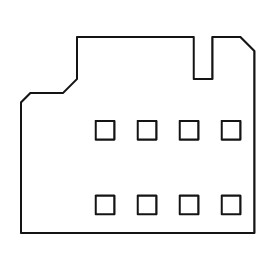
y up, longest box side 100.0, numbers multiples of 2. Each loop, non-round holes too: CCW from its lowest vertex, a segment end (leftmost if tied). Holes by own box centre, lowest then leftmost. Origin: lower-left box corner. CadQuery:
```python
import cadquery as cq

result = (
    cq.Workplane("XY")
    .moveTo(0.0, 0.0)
    .lineTo(100.0, 0.0)
    .lineTo(100.0, 78.0)
    .lineTo(94.0, 84.0)
    .lineTo(82.0, 84.0)
    .lineTo(82.0, 66.0)
    .lineTo(74.0, 66.0)
    .lineTo(74.0, 84.0)
    .lineTo(24.0, 84.0)
    .lineTo(24.0, 66.0)
    .lineTo(18.0, 60.0)
    .lineTo(4.0, 60.0)
    .lineTo(0.0, 56.0)
    .close()
    .moveTo(32.0, 8.0)
    .lineTo(40.0, 8.0)
    .lineTo(40.0, 16.0)
    .lineTo(32.0, 16.0)
    .close()
    .moveTo(50.0, 8.0)
    .lineTo(58.0, 8.0)
    .lineTo(58.0, 16.0)
    .lineTo(50.0, 16.0)
    .close()
    .moveTo(68.0, 8.0)
    .lineTo(76.0, 8.0)
    .lineTo(76.0, 16.0)
    .lineTo(68.0, 16.0)
    .close()
    .moveTo(86.0, 8.0)
    .lineTo(94.0, 8.0)
    .lineTo(94.0, 16.0)
    .lineTo(86.0, 16.0)
    .close()
    .moveTo(32.0, 40.0)
    .lineTo(40.0, 40.0)
    .lineTo(40.0, 48.0)
    .lineTo(32.0, 48.0)
    .close()
    .moveTo(50.0, 40.0)
    .lineTo(58.0, 40.0)
    .lineTo(58.0, 48.0)
    .lineTo(50.0, 48.0)
    .close()
    .moveTo(68.0, 40.0)
    .lineTo(76.0, 40.0)
    .lineTo(76.0, 48.0)
    .lineTo(68.0, 48.0)
    .close()
    .moveTo(86.0, 40.0)
    .lineTo(94.0, 40.0)
    .lineTo(94.0, 48.0)
    .lineTo(86.0, 48.0)
    .close()
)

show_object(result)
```